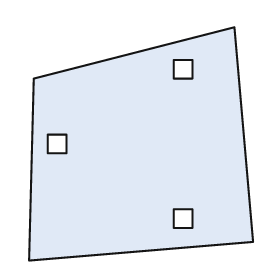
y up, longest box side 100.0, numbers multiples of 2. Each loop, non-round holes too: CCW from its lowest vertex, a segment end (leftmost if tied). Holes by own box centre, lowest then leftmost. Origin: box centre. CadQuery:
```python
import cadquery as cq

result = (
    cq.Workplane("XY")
    .moveTo(-48.0, -50.0)
    .lineTo(48.0, -42.0)
    .lineTo(40.0, 50.0)
    .lineTo(-46.0, 28.0)
    .close()
    .moveTo(14.0, -36.0)
    .lineTo(22.0, -36.0)
    .lineTo(22.0, -28.0)
    .lineTo(14.0, -28.0)
    .close()
    .moveTo(-40.0, -4.0)
    .lineTo(-32.0, -4.0)
    .lineTo(-32.0, 4.0)
    .lineTo(-40.0, 4.0)
    .close()
    .moveTo(14.0, 28.0)
    .lineTo(22.0, 28.0)
    .lineTo(22.0, 36.0)
    .lineTo(14.0, 36.0)
    .close()
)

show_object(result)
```